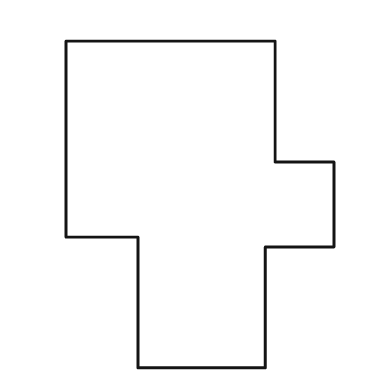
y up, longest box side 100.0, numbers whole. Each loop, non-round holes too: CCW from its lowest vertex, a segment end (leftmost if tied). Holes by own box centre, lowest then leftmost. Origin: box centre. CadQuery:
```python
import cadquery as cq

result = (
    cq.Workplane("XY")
    .moveTo(-19.0, -50.0)
    .lineTo(20.0, -50.0)
    .lineTo(20.0, -13.0)
    .lineTo(41.0, -13.0)
    .lineTo(41.0, 13.0)
    .lineTo(23.0, 13.0)
    .lineTo(23.0, 50.0)
    .lineTo(-41.0, 50.0)
    .lineTo(-41.0, -10.0)
    .lineTo(-19.0, -10.0)
    .close()
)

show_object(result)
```